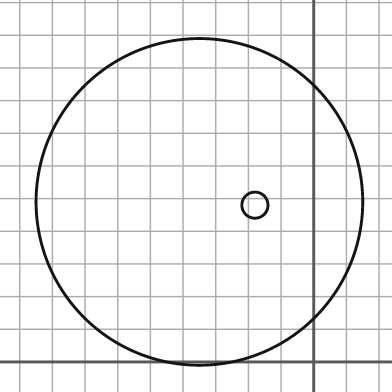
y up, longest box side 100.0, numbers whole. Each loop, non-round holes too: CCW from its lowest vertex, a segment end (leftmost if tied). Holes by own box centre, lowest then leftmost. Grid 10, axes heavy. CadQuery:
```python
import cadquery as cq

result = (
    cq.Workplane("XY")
    .moveTo(-35.0, 49.0)
    .circle(50.0)
    .moveTo(-18.0, 48.0)
    .circle(4.0)
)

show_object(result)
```